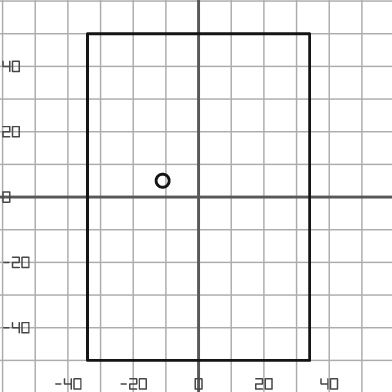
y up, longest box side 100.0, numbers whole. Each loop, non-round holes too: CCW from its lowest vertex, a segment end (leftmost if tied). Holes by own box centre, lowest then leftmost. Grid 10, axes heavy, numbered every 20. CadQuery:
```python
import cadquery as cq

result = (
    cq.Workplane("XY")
    .moveTo(-34.0, -50.0)
    .lineTo(34.0, -50.0)
    .lineTo(34.0, 50.0)
    .lineTo(-34.0, 50.0)
    .close()
    .moveTo(-11.0, 5.0)
    .circle(2.0)
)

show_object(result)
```